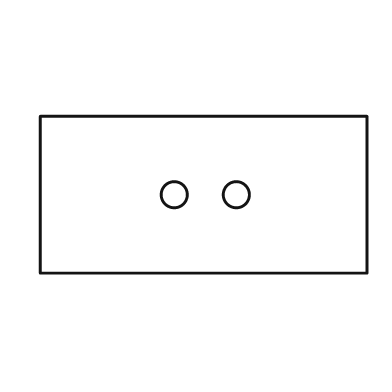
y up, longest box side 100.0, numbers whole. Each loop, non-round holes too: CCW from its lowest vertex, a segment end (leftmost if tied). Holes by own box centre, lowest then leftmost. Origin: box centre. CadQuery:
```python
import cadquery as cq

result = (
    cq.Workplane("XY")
    .moveTo(-50.0, -24.0)
    .lineTo(50.0, -24.0)
    .lineTo(50.0, 24.0)
    .lineTo(-50.0, 24.0)
    .close()
    .moveTo(-9.0, 0.0)
    .circle(4.0)
    .moveTo(10.0, 0.0)
    .circle(4.0)
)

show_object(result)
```